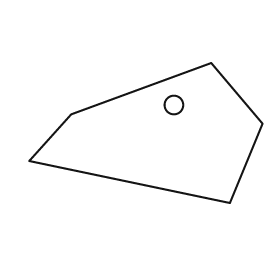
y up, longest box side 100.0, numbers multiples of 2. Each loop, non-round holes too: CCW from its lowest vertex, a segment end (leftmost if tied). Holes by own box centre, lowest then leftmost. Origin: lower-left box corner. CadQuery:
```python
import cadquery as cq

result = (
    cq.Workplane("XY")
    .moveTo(86.0, 0.0)
    .lineTo(100.0, 34.0)
    .lineTo(78.0, 60.0)
    .lineTo(18.0, 38.0)
    .lineTo(0.0, 18.0)
    .close()
    .moveTo(62.0, 42.0)
    .circle(4.0)
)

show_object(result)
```